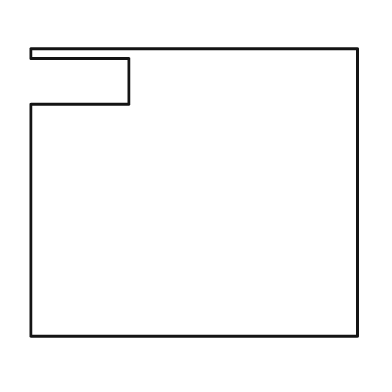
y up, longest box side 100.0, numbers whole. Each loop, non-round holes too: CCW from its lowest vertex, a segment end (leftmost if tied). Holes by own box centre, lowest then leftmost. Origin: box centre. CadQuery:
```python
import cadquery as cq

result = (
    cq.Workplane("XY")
    .moveTo(-50.0, -44.0)
    .lineTo(50.0, -44.0)
    .lineTo(50.0, 44.0)
    .lineTo(-50.0, 44.0)
    .lineTo(-50.0, 41.0)
    .lineTo(-20.0, 41.0)
    .lineTo(-20.0, 27.0)
    .lineTo(-50.0, 27.0)
    .close()
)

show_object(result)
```